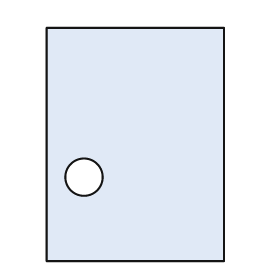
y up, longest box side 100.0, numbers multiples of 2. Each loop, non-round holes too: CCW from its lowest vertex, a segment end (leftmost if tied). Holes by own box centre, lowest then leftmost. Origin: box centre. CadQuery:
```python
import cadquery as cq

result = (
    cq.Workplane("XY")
    .moveTo(-38.0, -50.0)
    .lineTo(38.0, -50.0)
    .lineTo(38.0, 50.0)
    .lineTo(-38.0, 50.0)
    .close()
    .moveTo(-22.0, -14.0)
    .circle(8.0)
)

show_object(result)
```